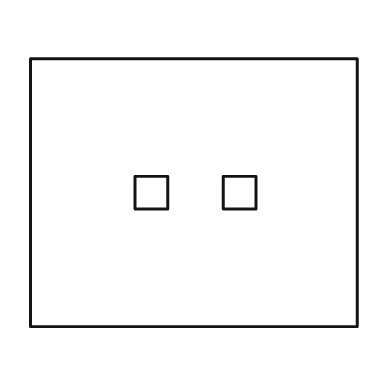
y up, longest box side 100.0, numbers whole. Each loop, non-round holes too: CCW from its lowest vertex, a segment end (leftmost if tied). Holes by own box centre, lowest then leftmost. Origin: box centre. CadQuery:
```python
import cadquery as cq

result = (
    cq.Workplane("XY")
    .moveTo(-50.0, -41.0)
    .lineTo(50.0, -41.0)
    .lineTo(50.0, 41.0)
    .lineTo(-50.0, 41.0)
    .close()
    .moveTo(-18.0, -5.0)
    .lineTo(-8.0, -5.0)
    .lineTo(-8.0, 5.0)
    .lineTo(-18.0, 5.0)
    .close()
    .moveTo(9.0, -5.0)
    .lineTo(19.0, -5.0)
    .lineTo(19.0, 5.0)
    .lineTo(9.0, 5.0)
    .close()
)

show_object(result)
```